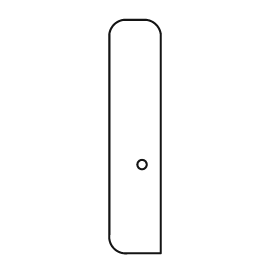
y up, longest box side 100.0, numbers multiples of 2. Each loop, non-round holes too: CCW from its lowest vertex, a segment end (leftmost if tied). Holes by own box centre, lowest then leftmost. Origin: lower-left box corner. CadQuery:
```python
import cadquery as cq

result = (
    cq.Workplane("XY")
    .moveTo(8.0, 0.0)
    .lineTo(22.0, 0.0)
    .lineTo(22.0, 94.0)
    .threePointArc((20.0, 98.0), (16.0, 100.0))
    .lineTo(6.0, 100.0)
    .threePointArc((2.0, 98.0), (0.0, 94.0))
    .lineTo(0.0, 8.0)
    .threePointArc((2.0, 2.0), (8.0, 0.0))
    .close()
    .moveTo(14.0, 38.0)
    .circle(2.0)
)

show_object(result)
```